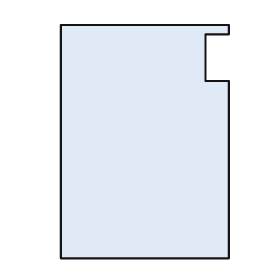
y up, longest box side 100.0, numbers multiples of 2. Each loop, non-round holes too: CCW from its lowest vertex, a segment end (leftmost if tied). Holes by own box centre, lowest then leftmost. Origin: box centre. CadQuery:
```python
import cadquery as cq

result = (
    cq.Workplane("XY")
    .moveTo(-36.0, -50.0)
    .lineTo(36.0, -50.0)
    .lineTo(36.0, 26.0)
    .lineTo(26.0, 26.0)
    .lineTo(26.0, 46.0)
    .lineTo(36.0, 46.0)
    .lineTo(36.0, 50.0)
    .lineTo(-36.0, 50.0)
    .close()
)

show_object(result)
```